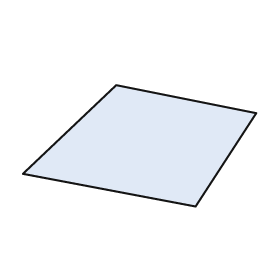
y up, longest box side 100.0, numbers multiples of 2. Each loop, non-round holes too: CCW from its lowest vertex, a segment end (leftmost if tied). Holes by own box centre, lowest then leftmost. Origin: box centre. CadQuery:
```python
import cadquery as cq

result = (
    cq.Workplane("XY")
    .moveTo(24.0, -26.0)
    .lineTo(50.0, 14.0)
    .lineTo(-10.0, 26.0)
    .lineTo(-50.0, -12.0)
    .close()
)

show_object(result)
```